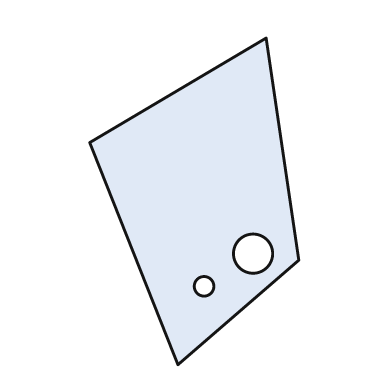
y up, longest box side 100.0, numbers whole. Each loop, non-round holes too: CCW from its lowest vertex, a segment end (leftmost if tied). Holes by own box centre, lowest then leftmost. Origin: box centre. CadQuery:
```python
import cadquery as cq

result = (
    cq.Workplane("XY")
    .moveTo(-5.0, -50.0)
    .lineTo(32.0, -18.0)
    .lineTo(22.0, 50.0)
    .lineTo(-32.0, 18.0)
    .close()
    .moveTo(3.0, -26.0)
    .circle(3.0)
    .moveTo(18.0, -16.0)
    .circle(6.0)
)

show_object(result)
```